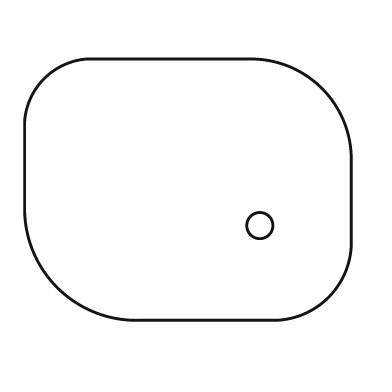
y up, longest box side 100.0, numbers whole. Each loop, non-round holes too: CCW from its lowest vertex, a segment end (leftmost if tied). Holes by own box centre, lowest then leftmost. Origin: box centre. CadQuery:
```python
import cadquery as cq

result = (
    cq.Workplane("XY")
    .moveTo(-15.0, -40.0)
    .lineTo(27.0, -40.0)
    .threePointArc((43.0, -33.0), (50.0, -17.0))
    .lineTo(50.0, 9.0)
    .threePointArc((41.0, 31.0), (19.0, 40.0))
    .lineTo(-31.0, 40.0)
    .threePointArc((-44.0, 34.0), (-50.0, 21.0))
    .lineTo(-50.0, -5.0)
    .threePointArc((-40.0, -30.0), (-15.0, -40.0))
    .close()
    .moveTo(22.0, -11.0)
    .circle(4.0)
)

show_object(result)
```